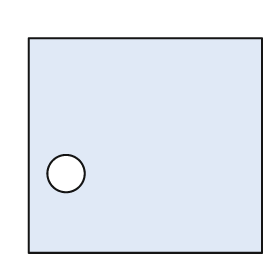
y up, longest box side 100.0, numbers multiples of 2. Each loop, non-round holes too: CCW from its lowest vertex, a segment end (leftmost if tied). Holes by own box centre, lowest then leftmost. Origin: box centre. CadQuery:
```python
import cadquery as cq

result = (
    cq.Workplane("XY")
    .moveTo(-50.0, -46.0)
    .lineTo(50.0, -46.0)
    .lineTo(50.0, 46.0)
    .lineTo(-50.0, 46.0)
    .close()
    .moveTo(-34.0, -12.0)
    .circle(8.0)
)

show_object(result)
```